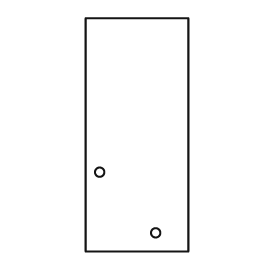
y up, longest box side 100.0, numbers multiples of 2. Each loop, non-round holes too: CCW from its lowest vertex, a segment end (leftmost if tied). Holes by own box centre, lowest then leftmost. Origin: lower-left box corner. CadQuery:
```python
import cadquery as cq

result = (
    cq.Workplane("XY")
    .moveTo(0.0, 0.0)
    .lineTo(44.0, 0.0)
    .lineTo(44.0, 100.0)
    .lineTo(0.0, 100.0)
    .close()
    .moveTo(30.0, 8.0)
    .circle(2.0)
    .moveTo(6.0, 34.0)
    .circle(2.0)
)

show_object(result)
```